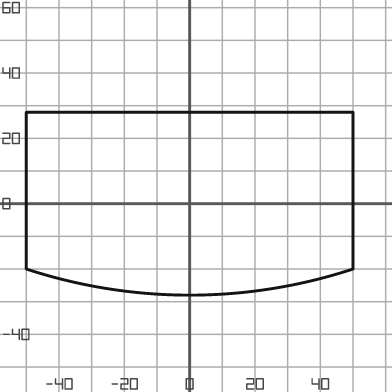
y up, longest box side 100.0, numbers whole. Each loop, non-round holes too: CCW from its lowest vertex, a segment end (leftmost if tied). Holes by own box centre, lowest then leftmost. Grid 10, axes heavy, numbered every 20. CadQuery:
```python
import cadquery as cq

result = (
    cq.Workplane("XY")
    .moveTo(-50.0, -20.0)
    .threePointArc((0.0, -28.0), (50.0, -20.0))
    .lineTo(50.0, 28.0)
    .lineTo(-50.0, 28.0)
    .close()
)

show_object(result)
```